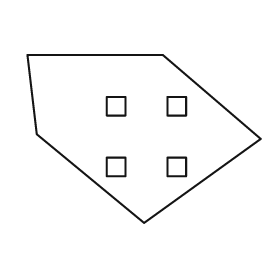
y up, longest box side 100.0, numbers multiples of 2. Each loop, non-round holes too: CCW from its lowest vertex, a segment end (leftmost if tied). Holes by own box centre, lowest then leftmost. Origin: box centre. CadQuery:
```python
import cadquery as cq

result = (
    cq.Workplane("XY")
    .moveTo(0.0, -36.0)
    .lineTo(50.0, 0.0)
    .lineTo(8.0, 36.0)
    .lineTo(-50.0, 36.0)
    .lineTo(-46.0, 2.0)
    .close()
    .moveTo(-16.0, -16.0)
    .lineTo(-8.0, -16.0)
    .lineTo(-8.0, -8.0)
    .lineTo(-16.0, -8.0)
    .close()
    .moveTo(10.0, -16.0)
    .lineTo(18.0, -16.0)
    .lineTo(18.0, -8.0)
    .lineTo(10.0, -8.0)
    .close()
    .moveTo(-16.0, 10.0)
    .lineTo(-8.0, 10.0)
    .lineTo(-8.0, 18.0)
    .lineTo(-16.0, 18.0)
    .close()
    .moveTo(10.0, 10.0)
    .lineTo(18.0, 10.0)
    .lineTo(18.0, 18.0)
    .lineTo(10.0, 18.0)
    .close()
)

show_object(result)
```